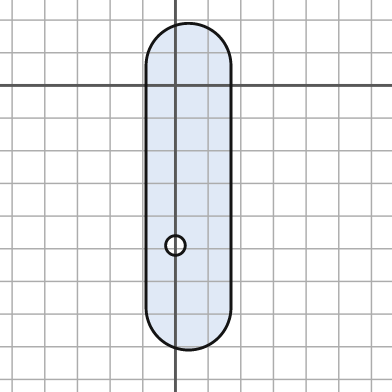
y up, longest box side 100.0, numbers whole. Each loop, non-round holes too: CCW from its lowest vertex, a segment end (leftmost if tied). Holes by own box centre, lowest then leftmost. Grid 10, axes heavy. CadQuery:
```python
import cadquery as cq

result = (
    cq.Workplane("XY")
    .moveTo(-9.0, -68.0)
    .threePointArc((4.0, -81.0), (17.0, -68.0))
    .lineTo(17.0, 6.0)
    .threePointArc((4.0, 19.0), (-9.0, 6.0))
    .close()
    .moveTo(0.0, -49.0)
    .circle(3.0)
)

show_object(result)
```